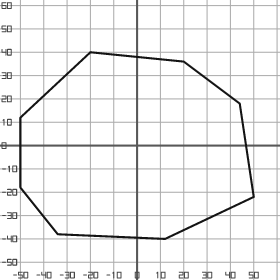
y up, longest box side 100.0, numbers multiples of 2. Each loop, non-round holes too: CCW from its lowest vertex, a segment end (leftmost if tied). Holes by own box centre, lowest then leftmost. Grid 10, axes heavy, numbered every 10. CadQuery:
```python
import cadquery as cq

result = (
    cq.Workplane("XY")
    .moveTo(12.0, -40.0)
    .lineTo(50.0, -22.0)
    .lineTo(44.0, 18.0)
    .lineTo(20.0, 36.0)
    .lineTo(-20.0, 40.0)
    .lineTo(-50.0, 12.0)
    .lineTo(-50.0, -18.0)
    .lineTo(-34.0, -38.0)
    .close()
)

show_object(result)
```